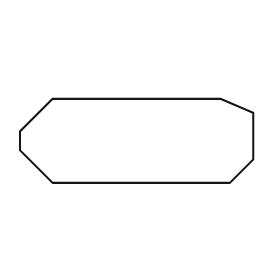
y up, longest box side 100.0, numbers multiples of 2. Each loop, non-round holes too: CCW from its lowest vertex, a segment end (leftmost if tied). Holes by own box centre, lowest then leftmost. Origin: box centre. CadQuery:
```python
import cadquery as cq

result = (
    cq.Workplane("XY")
    .moveTo(-36.0, -18.0)
    .lineTo(40.0, -18.0)
    .lineTo(50.0, -8.0)
    .lineTo(50.0, 12.0)
    .lineTo(36.0, 18.0)
    .lineTo(-36.0, 18.0)
    .lineTo(-50.0, 4.0)
    .lineTo(-50.0, -4.0)
    .close()
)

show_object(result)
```